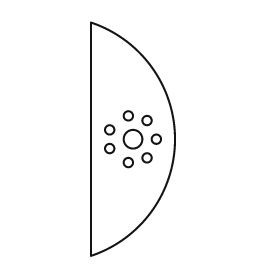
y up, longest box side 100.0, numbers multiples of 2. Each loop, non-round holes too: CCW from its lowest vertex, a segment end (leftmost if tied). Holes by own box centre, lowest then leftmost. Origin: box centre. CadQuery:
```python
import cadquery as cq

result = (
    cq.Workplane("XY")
    .moveTo(-18.0, -50.0)
    .threePointArc((18.0, 0.0), (-18.0, 50.0))
    .close()
    .moveTo(-2.0, -10.0)
    .circle(2.0)
    .moveTo(6.0, -8.0)
    .circle(2.0)
    .moveTo(-10.0, -4.0)
    .circle(2.0)
    .moveTo(0.0, 0.0)
    .circle(4.0)
    .moveTo(10.0, 0.0)
    .circle(2.0)
    .moveTo(-10.0, 4.0)
    .circle(2.0)
    .moveTo(6.0, 8.0)
    .circle(2.0)
    .moveTo(-2.0, 10.0)
    .circle(2.0)
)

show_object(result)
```